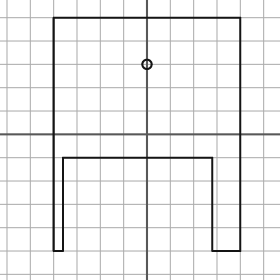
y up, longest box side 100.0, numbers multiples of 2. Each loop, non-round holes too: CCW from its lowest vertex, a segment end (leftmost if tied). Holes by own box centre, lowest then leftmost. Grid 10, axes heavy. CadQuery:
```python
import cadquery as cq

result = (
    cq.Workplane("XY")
    .moveTo(-40.0, -50.0)
    .lineTo(-36.0, -50.0)
    .lineTo(-36.0, -10.0)
    .lineTo(28.0, -10.0)
    .lineTo(28.0, -50.0)
    .lineTo(40.0, -50.0)
    .lineTo(40.0, 50.0)
    .lineTo(-40.0, 50.0)
    .close()
    .moveTo(0.0, 30.0)
    .circle(2.0)
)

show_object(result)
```